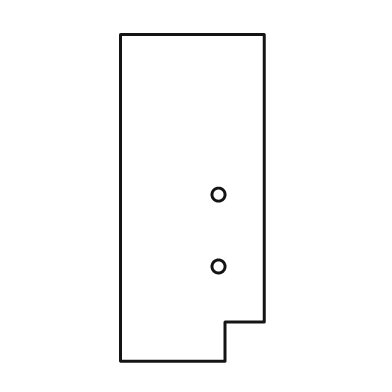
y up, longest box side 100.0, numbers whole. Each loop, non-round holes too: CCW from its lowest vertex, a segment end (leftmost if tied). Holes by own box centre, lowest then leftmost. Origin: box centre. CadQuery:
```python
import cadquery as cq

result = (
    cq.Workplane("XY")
    .moveTo(-22.0, -50.0)
    .lineTo(10.0, -50.0)
    .lineTo(10.0, -38.0)
    .lineTo(22.0, -38.0)
    .lineTo(22.0, 50.0)
    .lineTo(-22.0, 50.0)
    .close()
    .moveTo(8.0, -21.0)
    .circle(2.0)
    .moveTo(8.0, 1.0)
    .circle(2.0)
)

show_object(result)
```